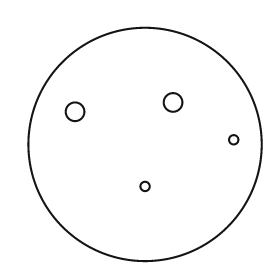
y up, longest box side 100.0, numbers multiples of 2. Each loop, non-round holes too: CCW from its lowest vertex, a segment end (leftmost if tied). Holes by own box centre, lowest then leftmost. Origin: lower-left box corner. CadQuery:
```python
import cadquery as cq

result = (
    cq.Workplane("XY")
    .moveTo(50.0, 50.0)
    .circle(50.0)
    .moveTo(50.0, 32.0)
    .circle(2.0)
    .moveTo(88.0, 52.0)
    .circle(2.0)
    .moveTo(20.0, 64.0)
    .circle(4.0)
    .moveTo(62.0, 68.0)
    .circle(4.0)
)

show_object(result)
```